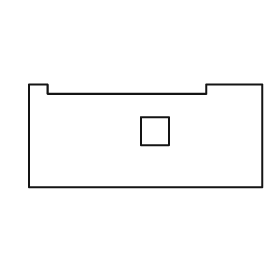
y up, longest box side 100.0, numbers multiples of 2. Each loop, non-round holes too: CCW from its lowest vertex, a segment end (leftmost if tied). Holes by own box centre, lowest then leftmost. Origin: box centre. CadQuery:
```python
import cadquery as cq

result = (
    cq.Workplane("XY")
    .moveTo(-50.0, -22.0)
    .lineTo(50.0, -22.0)
    .lineTo(50.0, 22.0)
    .lineTo(26.0, 22.0)
    .lineTo(26.0, 18.0)
    .lineTo(-42.0, 18.0)
    .lineTo(-42.0, 22.0)
    .lineTo(-50.0, 22.0)
    .close()
    .moveTo(-2.0, -4.0)
    .lineTo(10.0, -4.0)
    .lineTo(10.0, 8.0)
    .lineTo(-2.0, 8.0)
    .close()
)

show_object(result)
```